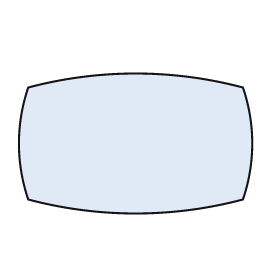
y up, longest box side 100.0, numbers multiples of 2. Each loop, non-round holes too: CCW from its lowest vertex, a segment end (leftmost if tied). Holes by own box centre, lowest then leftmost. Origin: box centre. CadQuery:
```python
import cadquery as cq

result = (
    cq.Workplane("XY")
    .moveTo(-46.0, -24.0)
    .threePointArc((0.0, -30.0), (46.0, -24.0))
    .threePointArc((50.0, 0.0), (46.0, 24.0))
    .threePointArc((0.0, 30.0), (-46.0, 24.0))
    .threePointArc((-50.0, 0.0), (-46.0, -24.0))
    .close()
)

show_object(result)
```